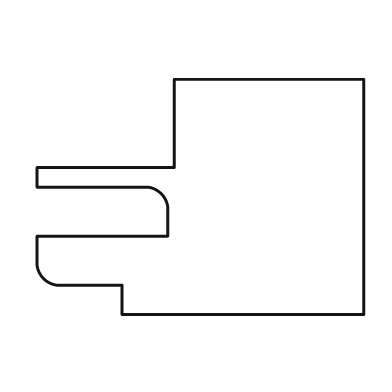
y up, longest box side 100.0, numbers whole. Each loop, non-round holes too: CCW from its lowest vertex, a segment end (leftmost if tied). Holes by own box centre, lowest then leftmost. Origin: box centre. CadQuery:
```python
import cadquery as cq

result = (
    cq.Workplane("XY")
    .moveTo(-24.0, -36.0)
    .lineTo(50.0, -36.0)
    .lineTo(50.0, 36.0)
    .lineTo(-8.0, 36.0)
    .lineTo(-8.0, 9.0)
    .lineTo(-50.0, 9.0)
    .lineTo(-50.0, 3.0)
    .lineTo(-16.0, 3.0)
    .threePointArc((-12.0, 1.0), (-10.0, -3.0))
    .lineTo(-10.0, -12.0)
    .lineTo(-50.0, -12.0)
    .lineTo(-50.0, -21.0)
    .threePointArc((-48.0, -25.0), (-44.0, -27.0))
    .lineTo(-24.0, -27.0)
    .close()
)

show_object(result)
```